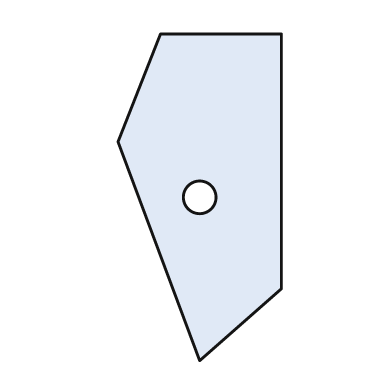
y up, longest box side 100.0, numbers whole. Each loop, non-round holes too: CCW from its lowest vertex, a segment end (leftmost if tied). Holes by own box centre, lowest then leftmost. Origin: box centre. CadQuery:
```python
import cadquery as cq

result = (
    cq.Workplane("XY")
    .moveTo(0.0, -50.0)
    .lineTo(25.0, -28.0)
    .lineTo(25.0, 50.0)
    .lineTo(-12.0, 50.0)
    .lineTo(-25.0, 17.0)
    .close()
    .moveTo(0.0, 0.0)
    .circle(5.0)
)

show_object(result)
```